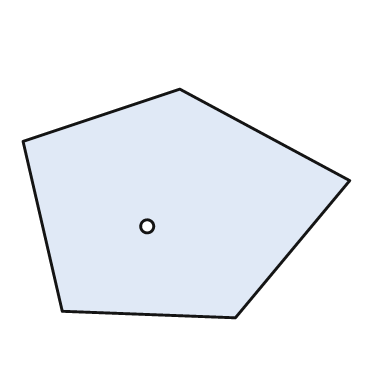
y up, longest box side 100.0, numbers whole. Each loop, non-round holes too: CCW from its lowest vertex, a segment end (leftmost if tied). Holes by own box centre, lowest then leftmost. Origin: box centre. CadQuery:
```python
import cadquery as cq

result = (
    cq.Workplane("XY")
    .moveTo(15.0, -35.0)
    .lineTo(50.0, 7.0)
    .lineTo(-2.0, 35.0)
    .lineTo(-50.0, 19.0)
    .lineTo(-38.0, -33.0)
    .close()
    .moveTo(-12.0, -7.0)
    .circle(2.0)
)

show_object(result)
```